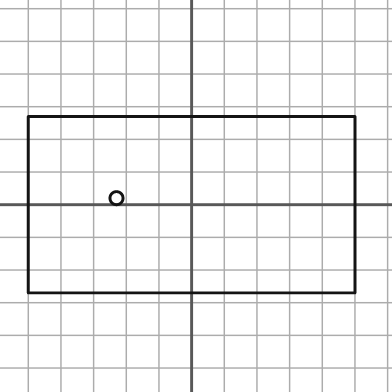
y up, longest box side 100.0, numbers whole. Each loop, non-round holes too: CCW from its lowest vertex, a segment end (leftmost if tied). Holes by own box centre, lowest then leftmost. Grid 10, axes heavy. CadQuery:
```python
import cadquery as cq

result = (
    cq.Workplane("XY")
    .moveTo(-50.0, -27.0)
    .lineTo(50.0, -27.0)
    .lineTo(50.0, 27.0)
    .lineTo(-50.0, 27.0)
    .close()
    .moveTo(-23.0, 2.0)
    .circle(2.0)
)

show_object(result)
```